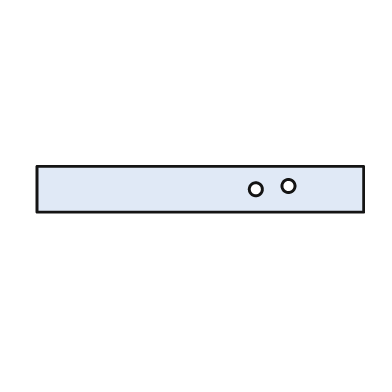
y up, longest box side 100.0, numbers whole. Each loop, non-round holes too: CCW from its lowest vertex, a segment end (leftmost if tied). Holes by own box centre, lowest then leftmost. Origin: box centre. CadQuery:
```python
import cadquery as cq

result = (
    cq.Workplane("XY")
    .moveTo(-50.0, -7.0)
    .lineTo(50.0, -7.0)
    .lineTo(50.0, 7.0)
    .lineTo(-50.0, 7.0)
    .close()
    .moveTo(17.0, 0.0)
    .circle(2.0)
    .moveTo(27.0, 1.0)
    .circle(2.0)
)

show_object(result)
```